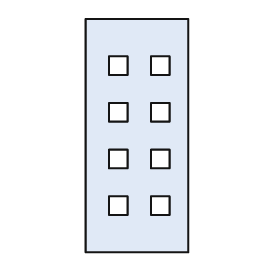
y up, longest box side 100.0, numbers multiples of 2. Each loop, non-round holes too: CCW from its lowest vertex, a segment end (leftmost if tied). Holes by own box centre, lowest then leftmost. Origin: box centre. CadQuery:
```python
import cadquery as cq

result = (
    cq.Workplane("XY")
    .moveTo(-22.0, -50.0)
    .lineTo(22.0, -50.0)
    .lineTo(22.0, 50.0)
    .lineTo(-22.0, 50.0)
    .close()
    .moveTo(-12.0, -34.0)
    .lineTo(-4.0, -34.0)
    .lineTo(-4.0, -26.0)
    .lineTo(-12.0, -26.0)
    .close()
    .moveTo(6.0, -34.0)
    .lineTo(14.0, -34.0)
    .lineTo(14.0, -26.0)
    .lineTo(6.0, -26.0)
    .close()
    .moveTo(-12.0, -14.0)
    .lineTo(-4.0, -14.0)
    .lineTo(-4.0, -6.0)
    .lineTo(-12.0, -6.0)
    .close()
    .moveTo(6.0, -14.0)
    .lineTo(14.0, -14.0)
    .lineTo(14.0, -6.0)
    .lineTo(6.0, -6.0)
    .close()
    .moveTo(-12.0, 6.0)
    .lineTo(-4.0, 6.0)
    .lineTo(-4.0, 14.0)
    .lineTo(-12.0, 14.0)
    .close()
    .moveTo(6.0, 6.0)
    .lineTo(14.0, 6.0)
    .lineTo(14.0, 14.0)
    .lineTo(6.0, 14.0)
    .close()
    .moveTo(-12.0, 26.0)
    .lineTo(-4.0, 26.0)
    .lineTo(-4.0, 34.0)
    .lineTo(-12.0, 34.0)
    .close()
    .moveTo(6.0, 26.0)
    .lineTo(14.0, 26.0)
    .lineTo(14.0, 34.0)
    .lineTo(6.0, 34.0)
    .close()
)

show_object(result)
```